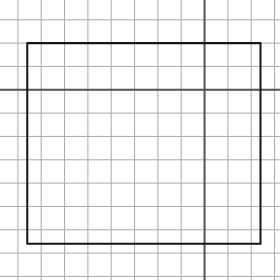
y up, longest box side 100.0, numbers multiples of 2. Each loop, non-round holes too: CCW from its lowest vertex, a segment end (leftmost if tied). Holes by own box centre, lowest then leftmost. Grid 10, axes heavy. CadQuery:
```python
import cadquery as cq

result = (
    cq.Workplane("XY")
    .moveTo(-76.0, -66.0)
    .lineTo(24.0, -66.0)
    .lineTo(24.0, 20.0)
    .lineTo(-76.0, 20.0)
    .close()
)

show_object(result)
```